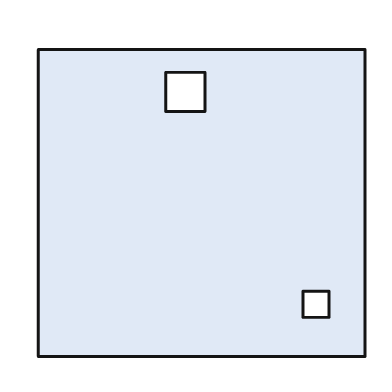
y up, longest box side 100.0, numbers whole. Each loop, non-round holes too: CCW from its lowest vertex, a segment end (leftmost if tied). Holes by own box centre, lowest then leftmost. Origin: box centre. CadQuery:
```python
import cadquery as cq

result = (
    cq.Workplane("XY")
    .moveTo(-50.0, -47.0)
    .lineTo(50.0, -47.0)
    .lineTo(50.0, 47.0)
    .lineTo(-50.0, 47.0)
    .close()
    .moveTo(31.0, -35.0)
    .lineTo(39.0, -35.0)
    .lineTo(39.0, -27.0)
    .lineTo(31.0, -27.0)
    .close()
    .moveTo(-11.0, 28.0)
    .lineTo(1.0, 28.0)
    .lineTo(1.0, 40.0)
    .lineTo(-11.0, 40.0)
    .close()
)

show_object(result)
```